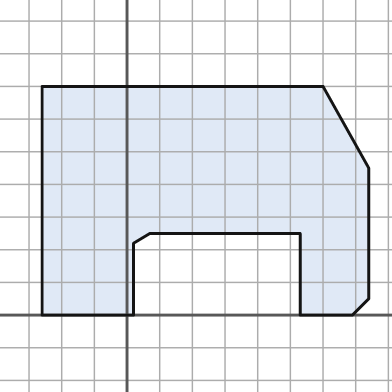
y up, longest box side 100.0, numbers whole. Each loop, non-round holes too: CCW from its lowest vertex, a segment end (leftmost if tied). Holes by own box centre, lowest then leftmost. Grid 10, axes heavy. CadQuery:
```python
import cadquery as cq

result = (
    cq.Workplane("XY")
    .moveTo(-26.0, 0.0)
    .lineTo(2.0, 0.0)
    .lineTo(2.0, 22.0)
    .lineTo(7.0, 25.0)
    .lineTo(53.0, 25.0)
    .lineTo(53.0, 0.0)
    .lineTo(69.0, 0.0)
    .lineTo(74.0, 5.0)
    .lineTo(74.0, 45.0)
    .lineTo(60.0, 70.0)
    .lineTo(-26.0, 70.0)
    .close()
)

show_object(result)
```